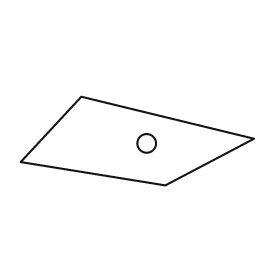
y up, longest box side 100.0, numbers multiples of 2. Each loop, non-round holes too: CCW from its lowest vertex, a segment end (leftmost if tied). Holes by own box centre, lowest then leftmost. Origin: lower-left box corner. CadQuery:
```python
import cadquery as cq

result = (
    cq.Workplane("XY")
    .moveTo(62.0, 0.0)
    .lineTo(100.0, 20.0)
    .lineTo(26.0, 38.0)
    .lineTo(0.0, 10.0)
    .close()
    .moveTo(54.0, 18.0)
    .circle(4.0)
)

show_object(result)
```